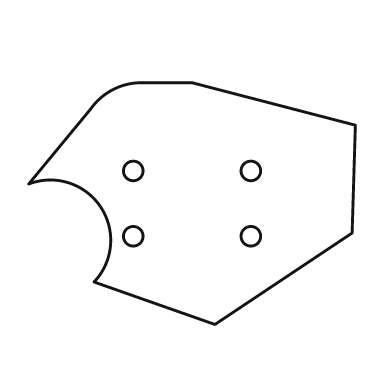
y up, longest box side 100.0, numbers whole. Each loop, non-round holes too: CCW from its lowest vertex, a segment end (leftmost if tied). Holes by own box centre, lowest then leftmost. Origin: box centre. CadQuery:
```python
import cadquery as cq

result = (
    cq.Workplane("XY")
    .moveTo(7.0, -37.0)
    .lineTo(49.0, -9.0)
    .lineTo(50.0, 24.0)
    .lineTo(0.0, 37.0)
    .lineTo(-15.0, 37.0)
    .threePointArc((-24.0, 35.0), (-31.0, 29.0))
    .lineTo(-50.0, 6.0)
    .threePointArc((-28.0, -1.0), (-30.0, -24.0))
    .close()
    .moveTo(-18.0, -10.0)
    .circle(3.0)
    .moveTo(18.0, -10.0)
    .circle(3.0)
    .moveTo(-18.0, 10.0)
    .circle(3.0)
    .moveTo(18.0, 10.0)
    .circle(3.0)
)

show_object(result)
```